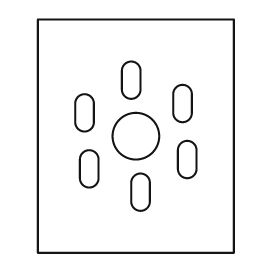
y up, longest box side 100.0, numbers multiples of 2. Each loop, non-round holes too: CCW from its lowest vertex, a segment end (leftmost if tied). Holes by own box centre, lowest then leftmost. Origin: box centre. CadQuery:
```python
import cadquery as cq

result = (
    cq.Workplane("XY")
    .moveTo(-42.0, -50.0)
    .lineTo(42.0, -50.0)
    .lineTo(42.0, 50.0)
    .lineTo(-42.0, 50.0)
    .close()
    .moveTo(-2.0, -28.0)
    .threePointArc((2.0, -32.0), (6.0, -28.0))
    .lineTo(6.0, -20.0)
    .threePointArc((2.0, -16.0), (-2.0, -20.0))
    .close()
    .moveTo(-24.0, -18.0)
    .threePointArc((-20.0, -22.0), (-16.0, -18.0))
    .lineTo(-16.0, -10.0)
    .threePointArc((-20.0, -6.0), (-24.0, -10.0))
    .close()
    .moveTo(18.0, -14.0)
    .threePointArc((22.0, -18.0), (26.0, -14.0))
    .lineTo(26.0, -6.0)
    .threePointArc((22.0, -2.0), (18.0, -6.0))
    .close()
    .moveTo(0.0, 0.0)
    .circle(10.0)
    .moveTo(-26.0, 6.0)
    .threePointArc((-22.0, 2.0), (-18.0, 6.0))
    .lineTo(-18.0, 14.0)
    .threePointArc((-22.0, 18.0), (-26.0, 14.0))
    .close()
    .moveTo(16.0, 10.0)
    .threePointArc((20.0, 6.0), (24.0, 10.0))
    .lineTo(24.0, 18.0)
    .threePointArc((20.0, 22.0), (16.0, 18.0))
    .close()
    .moveTo(-6.0, 20.0)
    .threePointArc((-2.0, 16.0), (2.0, 20.0))
    .lineTo(2.0, 28.0)
    .threePointArc((-2.0, 32.0), (-6.0, 28.0))
    .close()
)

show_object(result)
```